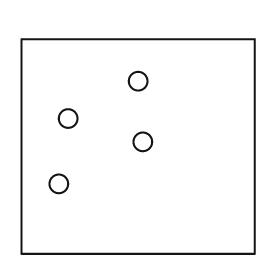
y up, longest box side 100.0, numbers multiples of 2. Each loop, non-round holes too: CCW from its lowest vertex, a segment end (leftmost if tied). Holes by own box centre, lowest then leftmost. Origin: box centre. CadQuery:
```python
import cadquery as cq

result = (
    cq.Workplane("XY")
    .moveTo(-50.0, -46.0)
    .lineTo(50.0, -46.0)
    .lineTo(50.0, 46.0)
    .lineTo(-50.0, 46.0)
    .close()
    .moveTo(-34.0, -16.0)
    .circle(4.0)
    .moveTo(2.0, 2.0)
    .circle(4.0)
    .moveTo(-30.0, 12.0)
    .circle(4.0)
    .moveTo(0.0, 28.0)
    .circle(4.0)
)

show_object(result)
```